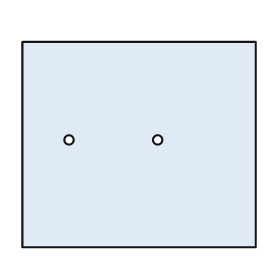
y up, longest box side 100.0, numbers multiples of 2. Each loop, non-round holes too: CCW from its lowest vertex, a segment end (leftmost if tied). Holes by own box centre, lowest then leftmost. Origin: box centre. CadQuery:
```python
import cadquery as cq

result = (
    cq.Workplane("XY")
    .moveTo(-50.0, -44.0)
    .lineTo(50.0, -44.0)
    .lineTo(50.0, 44.0)
    .lineTo(-50.0, 44.0)
    .close()
    .moveTo(-30.0, 2.0)
    .circle(2.0)
    .moveTo(8.0, 2.0)
    .circle(2.0)
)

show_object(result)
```